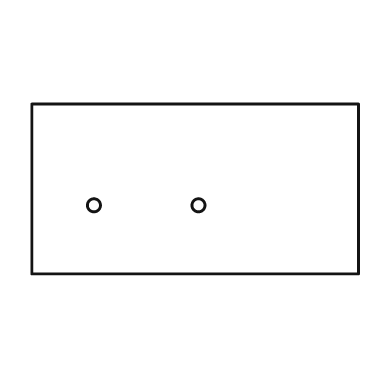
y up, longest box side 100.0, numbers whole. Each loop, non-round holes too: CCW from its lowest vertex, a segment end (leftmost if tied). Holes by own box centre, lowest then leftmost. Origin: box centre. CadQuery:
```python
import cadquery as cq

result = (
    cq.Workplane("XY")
    .moveTo(-50.0, -26.0)
    .lineTo(50.0, -26.0)
    .lineTo(50.0, 26.0)
    .lineTo(-50.0, 26.0)
    .close()
    .moveTo(-31.0, -5.0)
    .circle(2.0)
    .moveTo(1.0, -5.0)
    .circle(2.0)
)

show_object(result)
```